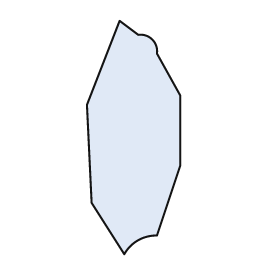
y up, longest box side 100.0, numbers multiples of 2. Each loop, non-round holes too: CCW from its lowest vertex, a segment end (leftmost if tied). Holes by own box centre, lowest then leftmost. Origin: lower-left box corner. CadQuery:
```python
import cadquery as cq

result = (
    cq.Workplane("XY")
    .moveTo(16.0, 0.0)
    .threePointArc((22.0, 6.0), (30.0, 8.0))
    .lineTo(40.0, 38.0)
    .lineTo(40.0, 68.0)
    .lineTo(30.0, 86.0)
    .threePointArc((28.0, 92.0), (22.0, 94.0))
    .lineTo(14.0, 100.0)
    .lineTo(0.0, 64.0)
    .lineTo(2.0, 22.0)
    .close()
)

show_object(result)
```